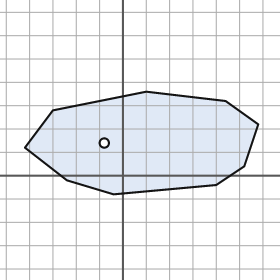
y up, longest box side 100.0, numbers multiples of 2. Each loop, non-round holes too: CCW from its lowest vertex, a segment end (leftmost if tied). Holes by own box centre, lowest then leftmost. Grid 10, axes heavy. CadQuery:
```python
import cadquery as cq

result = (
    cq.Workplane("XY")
    .moveTo(-4.0, -8.0)
    .lineTo(40.0, -4.0)
    .lineTo(52.0, 4.0)
    .lineTo(58.0, 22.0)
    .lineTo(44.0, 32.0)
    .lineTo(10.0, 36.0)
    .lineTo(-30.0, 28.0)
    .lineTo(-42.0, 12.0)
    .lineTo(-24.0, -2.0)
    .close()
    .moveTo(-8.0, 14.0)
    .circle(2.0)
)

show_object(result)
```